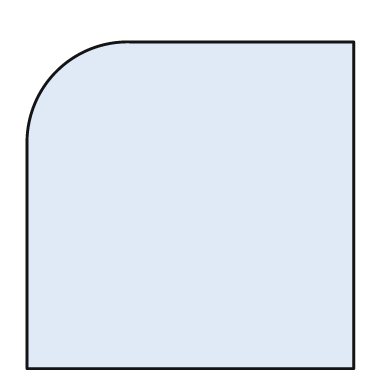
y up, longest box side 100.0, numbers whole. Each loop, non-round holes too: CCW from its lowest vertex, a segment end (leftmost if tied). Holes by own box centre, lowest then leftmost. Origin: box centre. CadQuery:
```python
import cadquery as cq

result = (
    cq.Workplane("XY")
    .moveTo(-50.0, -50.0)
    .lineTo(50.0, -50.0)
    .lineTo(50.0, 50.0)
    .lineTo(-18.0, 50.0)
    .threePointArc((-41.0, 41.0), (-50.0, 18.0))
    .close()
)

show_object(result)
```